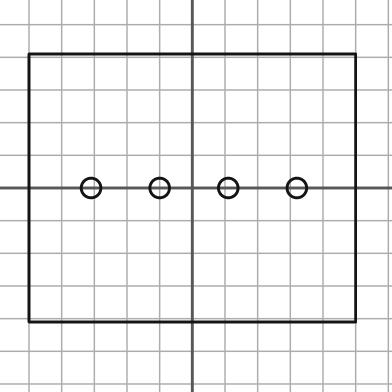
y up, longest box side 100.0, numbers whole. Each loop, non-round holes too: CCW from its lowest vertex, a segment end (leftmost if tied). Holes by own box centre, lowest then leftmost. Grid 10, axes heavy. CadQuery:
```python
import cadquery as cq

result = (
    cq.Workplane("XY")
    .moveTo(-50.0, -41.0)
    .lineTo(50.0, -41.0)
    .lineTo(50.0, 41.0)
    .lineTo(-50.0, 41.0)
    .close()
    .moveTo(-31.0, 0.0)
    .circle(3.0)
    .moveTo(-10.0, 0.0)
    .circle(3.0)
    .moveTo(11.0, 0.0)
    .circle(3.0)
    .moveTo(32.0, 0.0)
    .circle(3.0)
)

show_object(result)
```